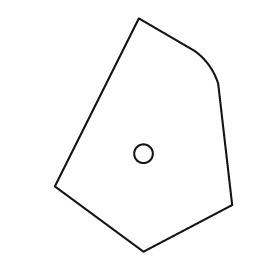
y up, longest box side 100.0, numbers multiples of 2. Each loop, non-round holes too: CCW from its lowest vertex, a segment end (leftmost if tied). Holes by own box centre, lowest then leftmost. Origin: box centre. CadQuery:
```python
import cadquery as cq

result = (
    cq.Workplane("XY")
    .moveTo(0.0, -50.0)
    .lineTo(38.0, -30.0)
    .lineTo(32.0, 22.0)
    .threePointArc((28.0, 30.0), (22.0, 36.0))
    .lineTo(-2.0, 50.0)
    .lineTo(-38.0, -22.0)
    .close()
    .moveTo(0.0, -8.0)
    .circle(4.0)
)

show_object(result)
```